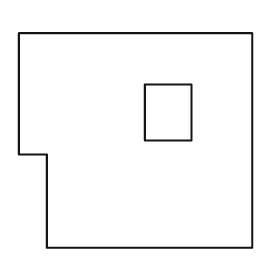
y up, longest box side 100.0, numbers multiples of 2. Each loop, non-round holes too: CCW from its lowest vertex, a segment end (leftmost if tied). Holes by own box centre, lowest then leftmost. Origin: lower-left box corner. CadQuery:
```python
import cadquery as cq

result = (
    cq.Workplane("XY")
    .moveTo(12.0, 0.0)
    .lineTo(100.0, 0.0)
    .lineTo(100.0, 92.0)
    .lineTo(0.0, 92.0)
    .lineTo(0.0, 40.0)
    .lineTo(12.0, 40.0)
    .close()
    .moveTo(54.0, 46.0)
    .lineTo(74.0, 46.0)
    .lineTo(74.0, 70.0)
    .lineTo(54.0, 70.0)
    .close()
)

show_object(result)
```